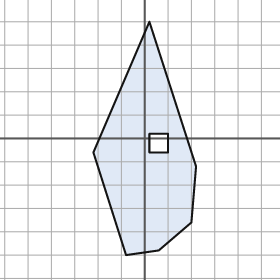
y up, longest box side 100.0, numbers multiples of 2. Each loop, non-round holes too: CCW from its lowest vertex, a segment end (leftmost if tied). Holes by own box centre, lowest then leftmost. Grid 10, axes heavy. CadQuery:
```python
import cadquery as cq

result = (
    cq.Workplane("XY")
    .moveTo(-8.0, -50.0)
    .lineTo(6.0, -48.0)
    .lineTo(20.0, -36.0)
    .lineTo(22.0, -12.0)
    .lineTo(2.0, 50.0)
    .lineTo(-22.0, -6.0)
    .close()
    .moveTo(2.0, -6.0)
    .lineTo(10.0, -6.0)
    .lineTo(10.0, 2.0)
    .lineTo(2.0, 2.0)
    .close()
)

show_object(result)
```